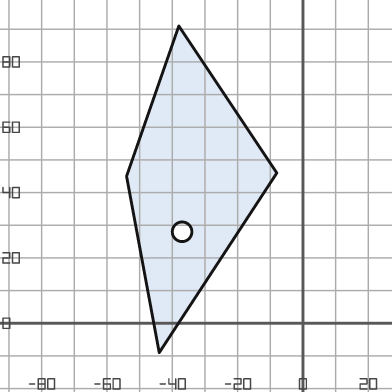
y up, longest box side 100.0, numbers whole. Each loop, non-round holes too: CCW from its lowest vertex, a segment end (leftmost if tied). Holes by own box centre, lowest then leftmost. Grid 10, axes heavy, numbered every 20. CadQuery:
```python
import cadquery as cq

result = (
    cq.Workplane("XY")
    .moveTo(-44.0, -9.0)
    .lineTo(-8.0, 46.0)
    .lineTo(-38.0, 91.0)
    .lineTo(-54.0, 45.0)
    .close()
    .moveTo(-37.0, 28.0)
    .circle(3.0)
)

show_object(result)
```